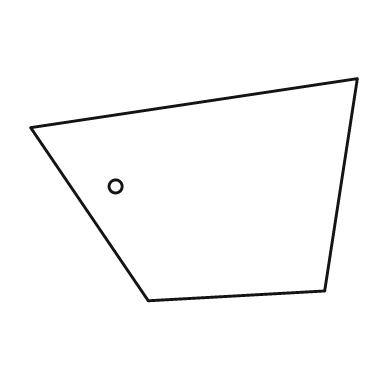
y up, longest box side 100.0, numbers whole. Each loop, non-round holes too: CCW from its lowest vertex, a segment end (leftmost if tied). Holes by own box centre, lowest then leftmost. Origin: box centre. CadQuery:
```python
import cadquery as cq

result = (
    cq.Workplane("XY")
    .moveTo(-14.0, -34.0)
    .lineTo(40.0, -31.0)
    .lineTo(50.0, 34.0)
    .lineTo(-50.0, 19.0)
    .close()
    .moveTo(-24.0, 1.0)
    .circle(2.0)
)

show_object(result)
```